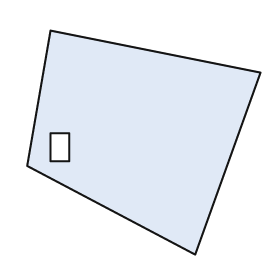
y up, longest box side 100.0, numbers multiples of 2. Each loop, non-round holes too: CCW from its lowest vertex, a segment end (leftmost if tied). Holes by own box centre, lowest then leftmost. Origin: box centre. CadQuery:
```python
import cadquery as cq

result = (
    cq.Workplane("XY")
    .moveTo(22.0, -48.0)
    .lineTo(50.0, 30.0)
    .lineTo(-40.0, 48.0)
    .lineTo(-50.0, -10.0)
    .close()
    .moveTo(-40.0, -8.0)
    .lineTo(-32.0, -8.0)
    .lineTo(-32.0, 4.0)
    .lineTo(-40.0, 4.0)
    .close()
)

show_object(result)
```